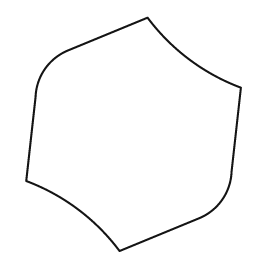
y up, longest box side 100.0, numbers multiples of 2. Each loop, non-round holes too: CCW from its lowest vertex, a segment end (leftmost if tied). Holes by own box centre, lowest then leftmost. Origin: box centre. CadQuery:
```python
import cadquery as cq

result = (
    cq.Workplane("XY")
    .moveTo(-6.0, -50.0)
    .lineTo(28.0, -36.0)
    .threePointArc((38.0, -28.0), (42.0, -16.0))
    .lineTo(46.0, 20.0)
    .threePointArc((24.0, 32.0), (6.0, 50.0))
    .lineTo(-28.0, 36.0)
    .threePointArc((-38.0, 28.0), (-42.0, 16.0))
    .lineTo(-46.0, -20.0)
    .threePointArc((-24.0, -32.0), (-6.0, -50.0))
    .close()
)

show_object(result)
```